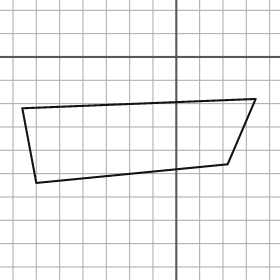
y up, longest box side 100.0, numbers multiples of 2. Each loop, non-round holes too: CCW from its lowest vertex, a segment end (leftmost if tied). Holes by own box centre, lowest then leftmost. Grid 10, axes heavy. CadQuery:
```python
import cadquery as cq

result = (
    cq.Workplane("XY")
    .moveTo(-60.0, -54.0)
    .lineTo(22.0, -46.0)
    .lineTo(34.0, -18.0)
    .lineTo(-66.0, -22.0)
    .close()
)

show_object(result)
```